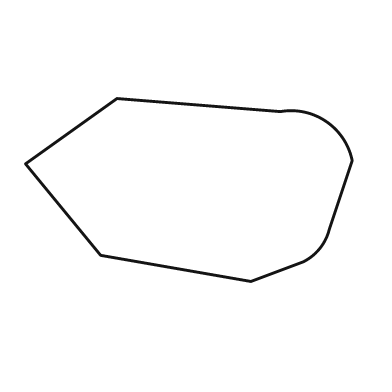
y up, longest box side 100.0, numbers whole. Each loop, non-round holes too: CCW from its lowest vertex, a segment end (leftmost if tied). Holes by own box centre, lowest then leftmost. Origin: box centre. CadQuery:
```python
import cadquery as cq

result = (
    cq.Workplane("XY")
    .moveTo(19.0, -28.0)
    .lineTo(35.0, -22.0)
    .threePointArc((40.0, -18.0), (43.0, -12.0))
    .lineTo(50.0, 9.0)
    .threePointArc((42.0, 21.0), (28.0, 24.0))
    .lineTo(-22.0, 28.0)
    .lineTo(-50.0, 8.0)
    .lineTo(-27.0, -20.0)
    .close()
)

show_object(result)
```